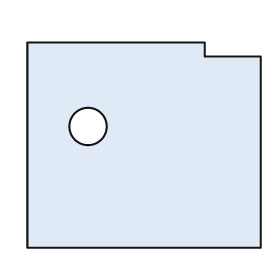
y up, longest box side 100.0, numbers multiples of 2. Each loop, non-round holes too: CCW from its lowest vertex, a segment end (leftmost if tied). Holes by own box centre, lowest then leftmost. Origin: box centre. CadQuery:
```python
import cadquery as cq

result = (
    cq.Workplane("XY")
    .moveTo(-50.0, -44.0)
    .lineTo(50.0, -44.0)
    .lineTo(50.0, 38.0)
    .lineTo(26.0, 38.0)
    .lineTo(26.0, 44.0)
    .lineTo(-50.0, 44.0)
    .close()
    .moveTo(-24.0, 8.0)
    .circle(8.0)
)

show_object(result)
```